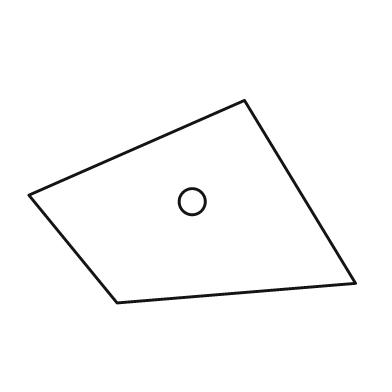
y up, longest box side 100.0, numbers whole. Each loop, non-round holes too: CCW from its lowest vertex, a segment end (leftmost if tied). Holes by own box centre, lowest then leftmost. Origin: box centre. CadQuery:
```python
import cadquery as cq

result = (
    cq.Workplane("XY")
    .moveTo(-23.0, -31.0)
    .lineTo(50.0, -25.0)
    .lineTo(16.0, 31.0)
    .lineTo(-50.0, 2.0)
    .close()
    .moveTo(0.0, 0.0)
    .circle(4.0)
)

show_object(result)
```